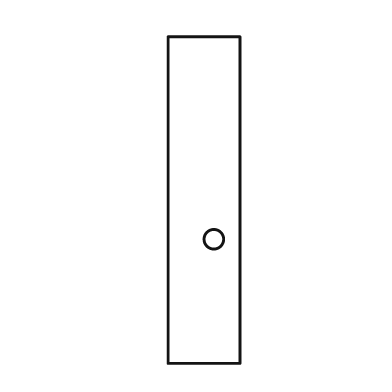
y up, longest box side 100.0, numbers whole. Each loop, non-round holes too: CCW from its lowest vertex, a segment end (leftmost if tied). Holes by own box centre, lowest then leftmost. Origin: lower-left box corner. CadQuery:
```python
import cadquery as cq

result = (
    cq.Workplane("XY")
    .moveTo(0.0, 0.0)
    .lineTo(22.0, 0.0)
    .lineTo(22.0, 100.0)
    .lineTo(0.0, 100.0)
    .close()
    .moveTo(14.0, 38.0)
    .circle(3.0)
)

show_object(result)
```